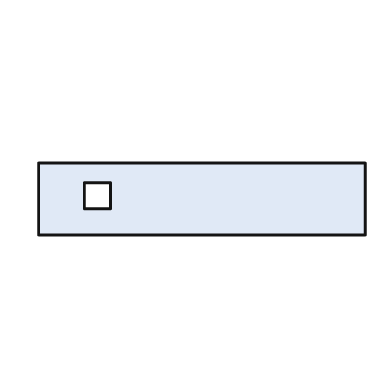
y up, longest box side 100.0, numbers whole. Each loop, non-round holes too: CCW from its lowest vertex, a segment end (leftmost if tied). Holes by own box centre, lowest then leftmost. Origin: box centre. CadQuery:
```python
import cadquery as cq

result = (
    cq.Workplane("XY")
    .moveTo(-50.0, -11.0)
    .lineTo(50.0, -11.0)
    .lineTo(50.0, 11.0)
    .lineTo(-50.0, 11.0)
    .close()
    .moveTo(-36.0, -3.0)
    .lineTo(-28.0, -3.0)
    .lineTo(-28.0, 5.0)
    .lineTo(-36.0, 5.0)
    .close()
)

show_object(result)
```